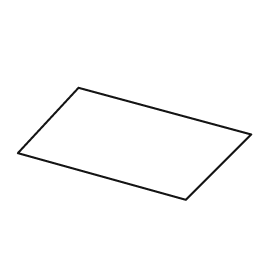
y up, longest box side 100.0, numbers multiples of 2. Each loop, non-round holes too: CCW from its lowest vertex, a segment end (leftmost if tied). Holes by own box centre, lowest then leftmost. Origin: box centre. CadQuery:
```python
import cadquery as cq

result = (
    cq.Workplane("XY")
    .moveTo(22.0, -24.0)
    .lineTo(50.0, 4.0)
    .lineTo(-24.0, 24.0)
    .lineTo(-50.0, -4.0)
    .close()
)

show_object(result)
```